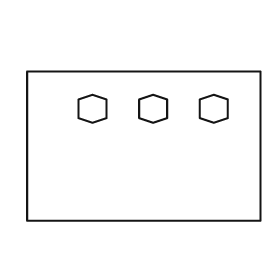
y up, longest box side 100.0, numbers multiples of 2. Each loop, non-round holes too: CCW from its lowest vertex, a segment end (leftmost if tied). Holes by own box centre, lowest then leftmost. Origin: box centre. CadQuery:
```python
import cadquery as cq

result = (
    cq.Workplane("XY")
    .moveTo(-50.0, -32.0)
    .lineTo(50.0, -32.0)
    .lineTo(50.0, 32.0)
    .lineTo(-50.0, 32.0)
    .close()
    .moveTo(-22.0, 10.0)
    .lineTo(-16.0, 12.0)
    .lineTo(-16.0, 20.0)
    .lineTo(-22.0, 22.0)
    .lineTo(-28.0, 20.0)
    .lineTo(-28.0, 12.0)
    .close()
    .moveTo(4.0, 10.0)
    .lineTo(10.0, 12.0)
    .lineTo(10.0, 20.0)
    .lineTo(4.0, 22.0)
    .lineTo(-2.0, 20.0)
    .lineTo(-2.0, 12.0)
    .close()
    .moveTo(30.0, 10.0)
    .lineTo(36.0, 12.0)
    .lineTo(36.0, 20.0)
    .lineTo(30.0, 22.0)
    .lineTo(24.0, 20.0)
    .lineTo(24.0, 12.0)
    .close()
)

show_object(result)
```